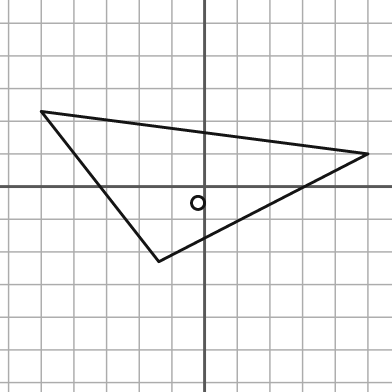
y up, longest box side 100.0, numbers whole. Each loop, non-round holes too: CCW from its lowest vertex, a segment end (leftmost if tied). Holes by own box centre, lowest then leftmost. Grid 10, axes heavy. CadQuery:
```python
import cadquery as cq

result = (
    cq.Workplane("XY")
    .moveTo(-14.0, -23.0)
    .lineTo(50.0, 10.0)
    .lineTo(-50.0, 23.0)
    .close()
    .moveTo(-2.0, -5.0)
    .circle(2.0)
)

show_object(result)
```